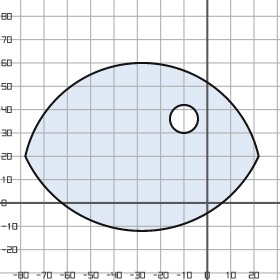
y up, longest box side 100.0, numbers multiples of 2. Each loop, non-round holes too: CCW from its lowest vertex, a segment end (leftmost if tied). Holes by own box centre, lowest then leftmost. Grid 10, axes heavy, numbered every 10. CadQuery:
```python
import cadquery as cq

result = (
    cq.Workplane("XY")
    .moveTo(-78.0, 20.0)
    .threePointArc((-28.0, -12.0), (22.0, 20.0))
    .threePointArc((-28.0, 60.0), (-78.0, 20.0))
    .close()
    .moveTo(-10.0, 36.0)
    .circle(6.0)
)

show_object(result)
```